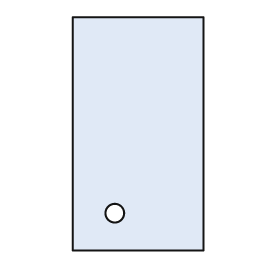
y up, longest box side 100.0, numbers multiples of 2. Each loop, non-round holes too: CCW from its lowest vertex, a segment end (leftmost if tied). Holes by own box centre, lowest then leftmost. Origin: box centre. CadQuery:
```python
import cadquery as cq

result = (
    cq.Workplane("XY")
    .moveTo(-28.0, -50.0)
    .lineTo(28.0, -50.0)
    .lineTo(28.0, 50.0)
    .lineTo(-28.0, 50.0)
    .close()
    .moveTo(-10.0, -34.0)
    .circle(4.0)
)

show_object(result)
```